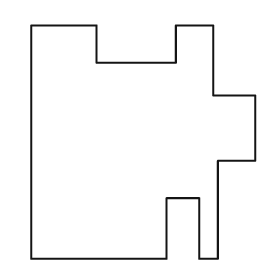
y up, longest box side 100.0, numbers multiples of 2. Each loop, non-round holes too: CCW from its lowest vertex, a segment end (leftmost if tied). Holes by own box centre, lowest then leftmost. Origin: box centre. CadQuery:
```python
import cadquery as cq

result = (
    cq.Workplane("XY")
    .moveTo(-48.0, -50.0)
    .lineTo(10.0, -50.0)
    .lineTo(10.0, -24.0)
    .lineTo(24.0, -24.0)
    .lineTo(24.0, -50.0)
    .lineTo(32.0, -50.0)
    .lineTo(32.0, -8.0)
    .lineTo(48.0, -8.0)
    .lineTo(48.0, 20.0)
    .lineTo(30.0, 20.0)
    .lineTo(30.0, 50.0)
    .lineTo(14.0, 50.0)
    .lineTo(14.0, 34.0)
    .lineTo(-20.0, 34.0)
    .lineTo(-20.0, 50.0)
    .lineTo(-48.0, 50.0)
    .close()
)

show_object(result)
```